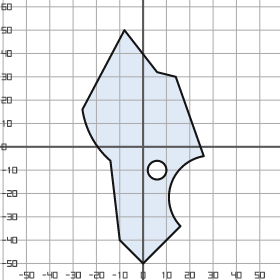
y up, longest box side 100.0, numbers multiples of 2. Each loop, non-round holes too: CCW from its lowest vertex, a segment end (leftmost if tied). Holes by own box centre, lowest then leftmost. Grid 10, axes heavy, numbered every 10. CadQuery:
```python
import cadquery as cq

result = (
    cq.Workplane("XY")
    .moveTo(0.0, -50.0)
    .lineTo(16.0, -34.0)
    .threePointArc((12.0, -16.0), (26.0, -4.0))
    .lineTo(14.0, 30.0)
    .lineTo(6.0, 32.0)
    .lineTo(-8.0, 50.0)
    .lineTo(-26.0, 16.0)
    .threePointArc((-22.0, 4.0), (-14.0, -6.0))
    .lineTo(-10.0, -40.0)
    .close()
    .moveTo(6.0, -10.0)
    .circle(4.0)
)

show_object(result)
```